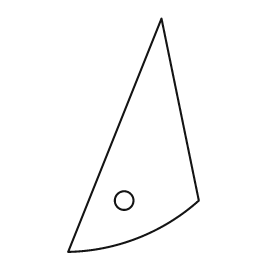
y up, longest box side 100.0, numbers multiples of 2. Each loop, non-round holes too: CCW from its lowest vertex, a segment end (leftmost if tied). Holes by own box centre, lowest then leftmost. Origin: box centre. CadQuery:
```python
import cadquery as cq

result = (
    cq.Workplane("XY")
    .moveTo(-28.0, -50.0)
    .threePointArc((2.0, -44.0), (28.0, -28.0))
    .lineTo(12.0, 50.0)
    .close()
    .moveTo(-4.0, -28.0)
    .circle(4.0)
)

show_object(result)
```